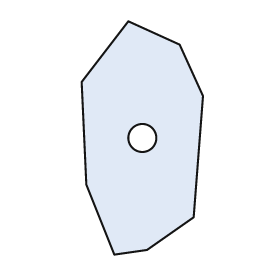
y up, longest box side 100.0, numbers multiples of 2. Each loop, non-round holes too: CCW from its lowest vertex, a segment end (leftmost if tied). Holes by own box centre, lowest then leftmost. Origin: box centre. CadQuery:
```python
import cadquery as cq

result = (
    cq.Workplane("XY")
    .moveTo(-12.0, -50.0)
    .lineTo(2.0, -48.0)
    .lineTo(22.0, -34.0)
    .lineTo(26.0, 18.0)
    .lineTo(16.0, 40.0)
    .lineTo(-6.0, 50.0)
    .lineTo(-26.0, 24.0)
    .lineTo(-24.0, -20.0)
    .close()
    .moveTo(0.0, 0.0)
    .circle(6.0)
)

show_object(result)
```